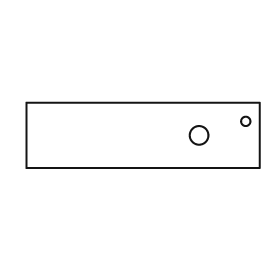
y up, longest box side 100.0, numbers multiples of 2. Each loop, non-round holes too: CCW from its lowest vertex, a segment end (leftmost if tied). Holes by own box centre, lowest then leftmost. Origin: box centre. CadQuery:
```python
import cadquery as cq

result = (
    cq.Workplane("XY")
    .moveTo(-50.0, -14.0)
    .lineTo(50.0, -14.0)
    .lineTo(50.0, 14.0)
    .lineTo(-50.0, 14.0)
    .close()
    .moveTo(24.0, 0.0)
    .circle(4.0)
    .moveTo(44.0, 6.0)
    .circle(2.0)
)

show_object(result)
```